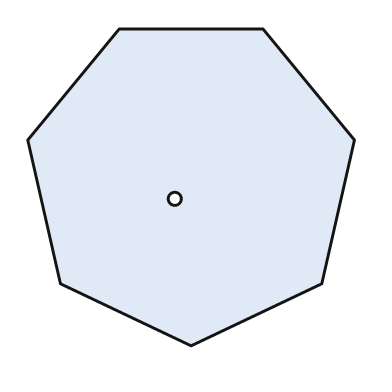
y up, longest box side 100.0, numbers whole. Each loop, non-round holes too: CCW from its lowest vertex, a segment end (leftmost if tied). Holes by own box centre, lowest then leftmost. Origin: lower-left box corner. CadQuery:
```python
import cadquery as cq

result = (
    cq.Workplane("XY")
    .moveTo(50.0, 0.0)
    .lineTo(90.0, 19.0)
    .lineTo(100.0, 63.0)
    .lineTo(72.0, 97.0)
    .lineTo(28.0, 97.0)
    .lineTo(0.0, 63.0)
    .lineTo(10.0, 19.0)
    .close()
    .moveTo(45.0, 45.0)
    .circle(2.0)
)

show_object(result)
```